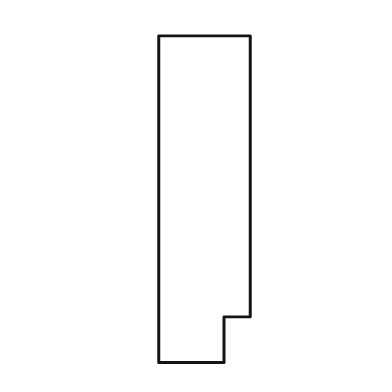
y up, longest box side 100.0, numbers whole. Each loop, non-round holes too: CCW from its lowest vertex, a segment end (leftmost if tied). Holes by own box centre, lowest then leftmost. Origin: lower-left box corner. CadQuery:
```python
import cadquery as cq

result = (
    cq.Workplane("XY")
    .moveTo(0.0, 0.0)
    .lineTo(20.0, 0.0)
    .lineTo(20.0, 14.0)
    .lineTo(28.0, 14.0)
    .lineTo(28.0, 100.0)
    .lineTo(0.0, 100.0)
    .close()
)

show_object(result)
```